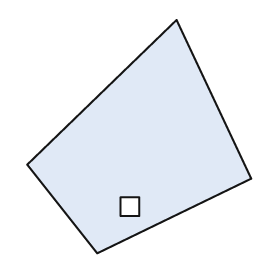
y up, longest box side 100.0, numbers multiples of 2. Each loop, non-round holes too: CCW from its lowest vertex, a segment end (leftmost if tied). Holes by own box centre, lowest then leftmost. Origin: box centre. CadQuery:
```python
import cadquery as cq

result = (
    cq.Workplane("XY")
    .moveTo(-18.0, -50.0)
    .lineTo(48.0, -18.0)
    .lineTo(16.0, 50.0)
    .lineTo(-48.0, -12.0)
    .close()
    .moveTo(-8.0, -34.0)
    .lineTo(0.0, -34.0)
    .lineTo(0.0, -26.0)
    .lineTo(-8.0, -26.0)
    .close()
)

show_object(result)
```